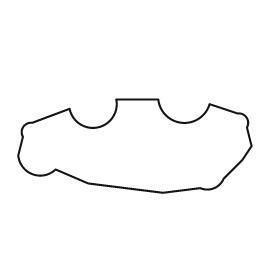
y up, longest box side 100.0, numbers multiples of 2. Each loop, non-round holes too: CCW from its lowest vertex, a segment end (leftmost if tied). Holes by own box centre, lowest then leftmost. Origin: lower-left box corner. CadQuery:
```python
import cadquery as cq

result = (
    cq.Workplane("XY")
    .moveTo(62.0, 0.0)
    .lineTo(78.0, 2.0)
    .threePointArc((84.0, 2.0), (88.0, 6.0))
    .lineTo(96.0, 14.0)
    .lineTo(100.0, 20.0)
    .lineTo(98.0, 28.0)
    .threePointArc((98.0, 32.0), (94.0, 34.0))
    .lineTo(82.0, 38.0)
    .threePointArc((70.0, 30.0), (60.0, 40.0))
    .lineTo(42.0, 40.0)
    .threePointArc((34.0, 28.0), (22.0, 36.0))
    .lineTo(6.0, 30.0)
    .threePointArc((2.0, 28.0), (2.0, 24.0))
    .lineTo(0.0, 16.0)
    .threePointArc((6.0, 8.0), (16.0, 10.0))
    .lineTo(30.0, 4.0)
    .close()
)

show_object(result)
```